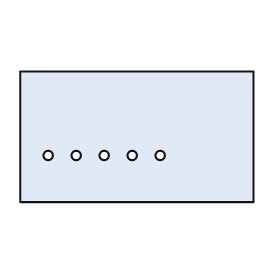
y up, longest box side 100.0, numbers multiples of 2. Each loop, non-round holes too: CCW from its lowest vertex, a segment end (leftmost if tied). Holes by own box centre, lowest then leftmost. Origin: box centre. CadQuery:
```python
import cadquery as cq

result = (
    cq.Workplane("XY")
    .moveTo(-50.0, -28.0)
    .lineTo(50.0, -28.0)
    .lineTo(50.0, 28.0)
    .lineTo(-50.0, 28.0)
    .close()
    .moveTo(-38.0, -8.0)
    .circle(2.0)
    .moveTo(-26.0, -8.0)
    .circle(2.0)
    .moveTo(-14.0, -8.0)
    .circle(2.0)
    .moveTo(-2.0, -8.0)
    .circle(2.0)
    .moveTo(10.0, -8.0)
    .circle(2.0)
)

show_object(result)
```